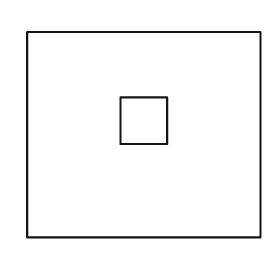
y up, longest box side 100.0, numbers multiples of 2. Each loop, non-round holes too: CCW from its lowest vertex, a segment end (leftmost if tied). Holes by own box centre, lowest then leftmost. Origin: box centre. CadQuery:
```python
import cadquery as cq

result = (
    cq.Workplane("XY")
    .moveTo(-50.0, -44.0)
    .lineTo(50.0, -44.0)
    .lineTo(50.0, 44.0)
    .lineTo(-50.0, 44.0)
    .close()
    .moveTo(-10.0, -4.0)
    .lineTo(10.0, -4.0)
    .lineTo(10.0, 16.0)
    .lineTo(-10.0, 16.0)
    .close()
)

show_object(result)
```